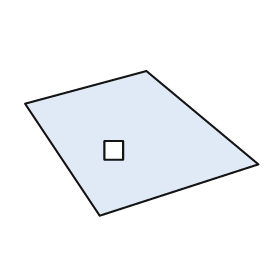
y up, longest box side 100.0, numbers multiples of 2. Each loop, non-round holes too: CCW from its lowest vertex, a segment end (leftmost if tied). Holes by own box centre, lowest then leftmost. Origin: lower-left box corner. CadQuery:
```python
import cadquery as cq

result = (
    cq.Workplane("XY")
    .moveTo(32.0, 0.0)
    .lineTo(100.0, 22.0)
    .lineTo(52.0, 62.0)
    .lineTo(0.0, 48.0)
    .close()
    .moveTo(34.0, 24.0)
    .lineTo(42.0, 24.0)
    .lineTo(42.0, 32.0)
    .lineTo(34.0, 32.0)
    .close()
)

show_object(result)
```